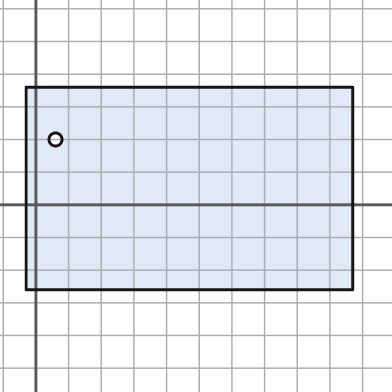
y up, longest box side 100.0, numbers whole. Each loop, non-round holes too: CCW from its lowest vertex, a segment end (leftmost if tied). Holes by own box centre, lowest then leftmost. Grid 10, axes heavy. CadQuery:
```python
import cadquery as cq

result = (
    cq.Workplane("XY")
    .moveTo(-3.0, -26.0)
    .lineTo(97.0, -26.0)
    .lineTo(97.0, 36.0)
    .lineTo(-3.0, 36.0)
    .close()
    .moveTo(6.0, 20.0)
    .circle(2.0)
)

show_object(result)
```